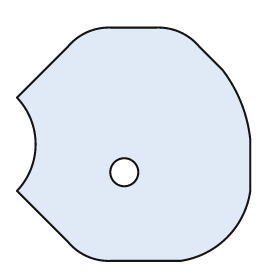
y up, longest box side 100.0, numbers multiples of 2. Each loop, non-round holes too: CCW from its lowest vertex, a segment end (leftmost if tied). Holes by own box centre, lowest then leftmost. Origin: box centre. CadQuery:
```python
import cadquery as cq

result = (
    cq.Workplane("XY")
    .moveTo(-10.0, -50.0)
    .lineTo(20.0, -50.0)
    .threePointArc((40.0, -40.0), (50.0, -20.0))
    .lineTo(50.0, 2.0)
    .threePointArc((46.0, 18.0), (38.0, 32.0))
    .lineTo(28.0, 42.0)
    .threePointArc((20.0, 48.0), (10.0, 50.0))
    .lineTo(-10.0, 50.0)
    .threePointArc((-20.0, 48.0), (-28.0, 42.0))
    .lineTo(-50.0, 20.0)
    .threePointArc((-42.0, 0.0), (-50.0, -20.0))
    .lineTo(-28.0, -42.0)
    .threePointArc((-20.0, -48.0), (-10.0, -50.0))
    .close()
    .moveTo(-4.0, -12.0)
    .circle(6.0)
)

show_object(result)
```